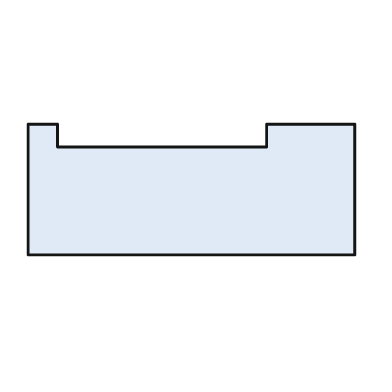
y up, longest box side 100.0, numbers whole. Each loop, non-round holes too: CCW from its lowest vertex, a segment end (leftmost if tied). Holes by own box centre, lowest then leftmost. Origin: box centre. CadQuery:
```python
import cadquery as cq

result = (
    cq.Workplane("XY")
    .moveTo(-50.0, -20.0)
    .lineTo(50.0, -20.0)
    .lineTo(50.0, 20.0)
    .lineTo(23.0, 20.0)
    .lineTo(23.0, 13.0)
    .lineTo(-41.0, 13.0)
    .lineTo(-41.0, 20.0)
    .lineTo(-50.0, 20.0)
    .close()
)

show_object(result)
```